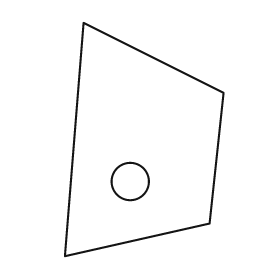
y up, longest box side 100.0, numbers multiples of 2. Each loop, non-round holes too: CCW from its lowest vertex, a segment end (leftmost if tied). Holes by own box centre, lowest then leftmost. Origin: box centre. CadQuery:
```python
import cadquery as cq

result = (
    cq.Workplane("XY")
    .moveTo(-34.0, -50.0)
    .lineTo(28.0, -36.0)
    .lineTo(34.0, 20.0)
    .lineTo(-26.0, 50.0)
    .close()
    .moveTo(-6.0, -18.0)
    .circle(8.0)
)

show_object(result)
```